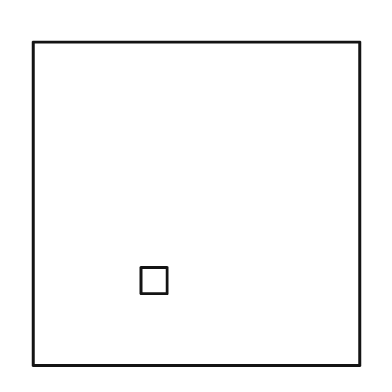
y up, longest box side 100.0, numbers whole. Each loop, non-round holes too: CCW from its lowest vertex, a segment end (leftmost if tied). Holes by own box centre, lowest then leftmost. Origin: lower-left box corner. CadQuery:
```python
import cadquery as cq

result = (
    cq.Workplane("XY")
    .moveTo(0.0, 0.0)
    .lineTo(100.0, 0.0)
    .lineTo(100.0, 99.0)
    .lineTo(0.0, 99.0)
    .close()
    .moveTo(33.0, 22.0)
    .lineTo(41.0, 22.0)
    .lineTo(41.0, 30.0)
    .lineTo(33.0, 30.0)
    .close()
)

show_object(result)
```